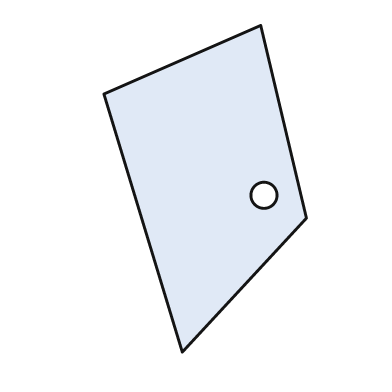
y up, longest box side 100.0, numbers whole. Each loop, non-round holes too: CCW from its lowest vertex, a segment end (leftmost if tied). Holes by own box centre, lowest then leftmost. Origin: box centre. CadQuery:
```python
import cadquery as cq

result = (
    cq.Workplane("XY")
    .moveTo(-7.0, -50.0)
    .lineTo(31.0, -9.0)
    .lineTo(17.0, 50.0)
    .lineTo(-31.0, 29.0)
    .close()
    .moveTo(18.0, -2.0)
    .circle(4.0)
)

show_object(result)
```